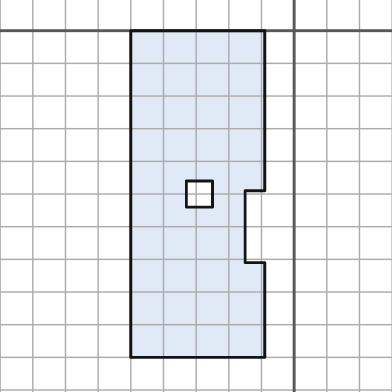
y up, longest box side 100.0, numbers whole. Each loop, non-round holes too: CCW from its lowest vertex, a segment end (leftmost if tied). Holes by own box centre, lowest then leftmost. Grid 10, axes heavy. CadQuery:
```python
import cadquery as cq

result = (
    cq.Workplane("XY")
    .moveTo(-50.0, -100.0)
    .lineTo(-9.0, -100.0)
    .lineTo(-9.0, -71.0)
    .lineTo(-15.0, -71.0)
    .lineTo(-15.0, -49.0)
    .lineTo(-9.0, -49.0)
    .lineTo(-9.0, 0.0)
    .lineTo(-50.0, 0.0)
    .close()
    .moveTo(-33.0, -54.0)
    .lineTo(-25.0, -54.0)
    .lineTo(-25.0, -46.0)
    .lineTo(-33.0, -46.0)
    .close()
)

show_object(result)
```